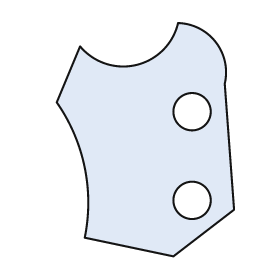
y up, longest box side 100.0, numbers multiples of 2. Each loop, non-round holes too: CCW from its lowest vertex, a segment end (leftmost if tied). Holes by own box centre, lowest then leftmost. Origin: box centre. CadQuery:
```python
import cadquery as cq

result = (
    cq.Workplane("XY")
    .moveTo(12.0, -50.0)
    .lineTo(38.0, -30.0)
    .lineTo(34.0, 24.0)
    .threePointArc((30.0, 42.0), (14.0, 50.0))
    .threePointArc((-4.0, 32.0), (-28.0, 40.0))
    .lineTo(-38.0, 16.0)
    .threePointArc((-26.0, -12.0), (-26.0, -42.0))
    .close()
    .moveTo(20.0, -26.0)
    .circle(8.0)
    .moveTo(20.0, 12.0)
    .circle(8.0)
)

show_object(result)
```